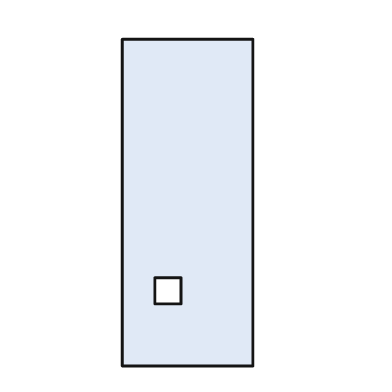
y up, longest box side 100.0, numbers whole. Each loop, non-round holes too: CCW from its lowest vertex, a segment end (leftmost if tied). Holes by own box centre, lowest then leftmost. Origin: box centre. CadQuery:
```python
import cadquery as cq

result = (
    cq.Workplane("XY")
    .moveTo(-20.0, -50.0)
    .lineTo(20.0, -50.0)
    .lineTo(20.0, 50.0)
    .lineTo(-20.0, 50.0)
    .close()
    .moveTo(-10.0, -31.0)
    .lineTo(-2.0, -31.0)
    .lineTo(-2.0, -23.0)
    .lineTo(-10.0, -23.0)
    .close()
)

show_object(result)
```